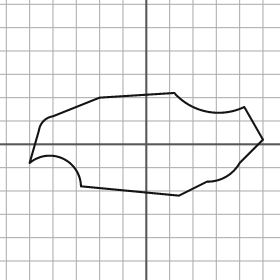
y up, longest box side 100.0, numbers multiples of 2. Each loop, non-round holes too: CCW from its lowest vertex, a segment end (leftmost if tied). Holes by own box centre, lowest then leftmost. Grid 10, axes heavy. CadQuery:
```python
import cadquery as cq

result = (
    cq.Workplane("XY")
    .moveTo(14.0, -22.0)
    .lineTo(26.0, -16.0)
    .threePointArc((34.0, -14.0), (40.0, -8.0))
    .lineTo(50.0, 2.0)
    .lineTo(42.0, 16.0)
    .threePointArc((26.0, 14.0), (12.0, 22.0))
    .lineTo(-20.0, 20.0)
    .lineTo(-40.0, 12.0)
    .threePointArc((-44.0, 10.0), (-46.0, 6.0))
    .lineTo(-50.0, -8.0)
    .threePointArc((-36.0, -6.0), (-28.0, -18.0))
    .close()
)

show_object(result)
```